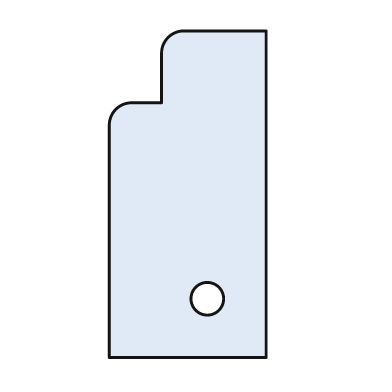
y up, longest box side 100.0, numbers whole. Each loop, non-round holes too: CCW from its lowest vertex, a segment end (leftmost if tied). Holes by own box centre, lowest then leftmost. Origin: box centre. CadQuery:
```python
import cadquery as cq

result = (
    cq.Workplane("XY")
    .moveTo(-24.0, -50.0)
    .lineTo(24.0, -50.0)
    .lineTo(24.0, 50.0)
    .lineTo(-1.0, 50.0)
    .threePointArc((-6.0, 48.0), (-8.0, 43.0))
    .lineTo(-8.0, 28.0)
    .lineTo(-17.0, 28.0)
    .threePointArc((-22.0, 26.0), (-24.0, 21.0))
    .close()
    .moveTo(6.0, -32.0)
    .circle(5.0)
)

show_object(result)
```